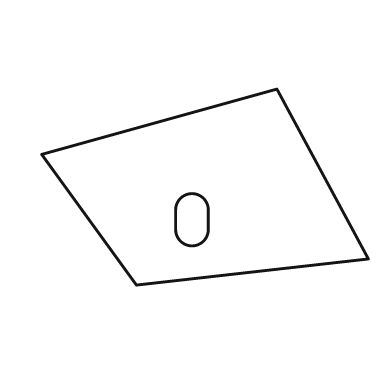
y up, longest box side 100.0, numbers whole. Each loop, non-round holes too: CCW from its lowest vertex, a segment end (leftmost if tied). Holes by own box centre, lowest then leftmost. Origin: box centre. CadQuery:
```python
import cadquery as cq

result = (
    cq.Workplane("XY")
    .moveTo(-21.0, -30.0)
    .lineTo(50.0, -22.0)
    .lineTo(22.0, 30.0)
    .lineTo(-50.0, 10.0)
    .close()
    .moveTo(-9.0, -13.0)
    .threePointArc((-4.0, -18.0), (1.0, -13.0))
    .lineTo(1.0, -7.0)
    .threePointArc((-4.0, -2.0), (-9.0, -7.0))
    .close()
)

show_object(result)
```